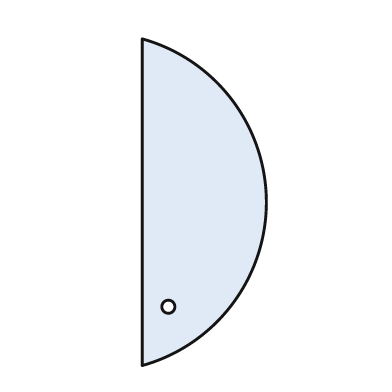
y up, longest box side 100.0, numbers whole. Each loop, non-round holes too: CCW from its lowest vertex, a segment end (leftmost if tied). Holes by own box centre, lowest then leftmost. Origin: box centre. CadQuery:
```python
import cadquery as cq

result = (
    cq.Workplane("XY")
    .moveTo(-19.0, -50.0)
    .threePointArc((19.0, 0.0), (-19.0, 50.0))
    .close()
    .moveTo(-11.0, -32.0)
    .circle(2.0)
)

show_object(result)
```